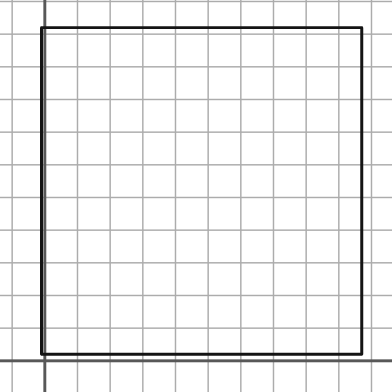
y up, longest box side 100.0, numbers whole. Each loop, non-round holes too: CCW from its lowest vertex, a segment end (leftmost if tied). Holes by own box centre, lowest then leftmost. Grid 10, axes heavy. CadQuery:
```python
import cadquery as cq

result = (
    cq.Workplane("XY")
    .moveTo(-1.0, 2.0)
    .lineTo(97.0, 2.0)
    .lineTo(97.0, 102.0)
    .lineTo(-1.0, 102.0)
    .close()
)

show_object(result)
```